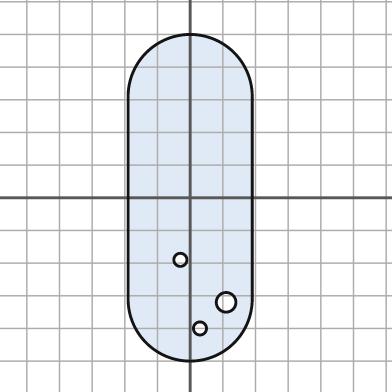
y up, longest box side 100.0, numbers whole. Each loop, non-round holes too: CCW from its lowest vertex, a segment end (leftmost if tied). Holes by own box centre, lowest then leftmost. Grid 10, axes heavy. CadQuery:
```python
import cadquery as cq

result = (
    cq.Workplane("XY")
    .moveTo(-19.0, -31.0)
    .threePointArc((0.0, -50.0), (19.0, -31.0))
    .lineTo(19.0, 31.0)
    .threePointArc((0.0, 50.0), (-19.0, 31.0))
    .close()
    .moveTo(3.0, -40.0)
    .circle(2.0)
    .moveTo(11.0, -32.0)
    .circle(3.0)
    .moveTo(-3.0, -19.0)
    .circle(2.0)
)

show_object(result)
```